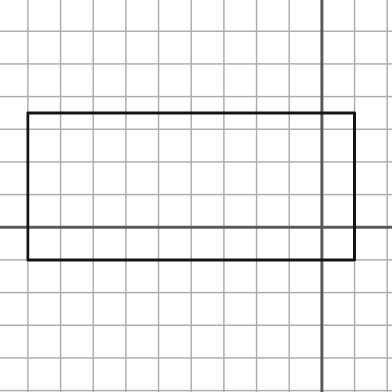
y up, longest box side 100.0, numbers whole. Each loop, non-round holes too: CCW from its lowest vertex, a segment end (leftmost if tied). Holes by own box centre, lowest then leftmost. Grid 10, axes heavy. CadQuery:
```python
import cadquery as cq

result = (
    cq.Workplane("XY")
    .moveTo(-90.0, -10.0)
    .lineTo(10.0, -10.0)
    .lineTo(10.0, 35.0)
    .lineTo(-90.0, 35.0)
    .close()
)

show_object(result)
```